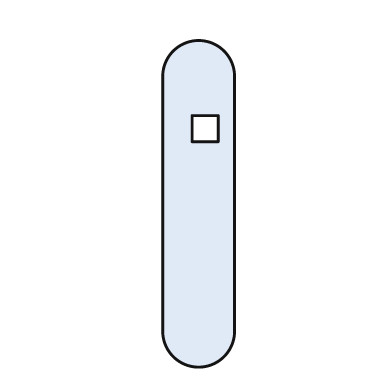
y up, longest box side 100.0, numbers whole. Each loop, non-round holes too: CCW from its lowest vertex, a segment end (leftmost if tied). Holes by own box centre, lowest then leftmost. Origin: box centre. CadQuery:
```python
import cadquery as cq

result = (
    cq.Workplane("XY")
    .moveTo(-11.0, -39.0)
    .threePointArc((0.0, -50.0), (11.0, -39.0))
    .lineTo(11.0, 39.0)
    .threePointArc((0.0, 50.0), (-11.0, 39.0))
    .close()
    .moveTo(-2.0, 19.0)
    .lineTo(6.0, 19.0)
    .lineTo(6.0, 27.0)
    .lineTo(-2.0, 27.0)
    .close()
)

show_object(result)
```